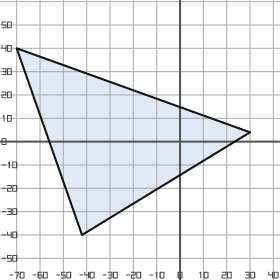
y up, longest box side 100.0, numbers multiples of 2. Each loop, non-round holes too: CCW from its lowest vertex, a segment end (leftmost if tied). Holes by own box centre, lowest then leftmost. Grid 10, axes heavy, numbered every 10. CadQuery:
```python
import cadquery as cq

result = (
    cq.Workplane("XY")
    .moveTo(-42.0, -40.0)
    .lineTo(30.0, 4.0)
    .lineTo(-70.0, 40.0)
    .close()
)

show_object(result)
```